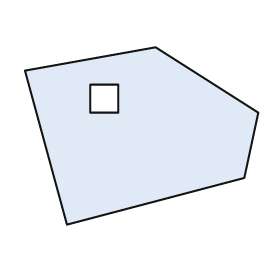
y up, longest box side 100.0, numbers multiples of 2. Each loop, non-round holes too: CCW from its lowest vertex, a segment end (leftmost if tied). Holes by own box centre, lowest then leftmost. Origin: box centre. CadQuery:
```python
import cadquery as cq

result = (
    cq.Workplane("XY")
    .moveTo(-32.0, -38.0)
    .lineTo(44.0, -18.0)
    .lineTo(50.0, 10.0)
    .lineTo(6.0, 38.0)
    .lineTo(-50.0, 28.0)
    .close()
    .moveTo(-22.0, 10.0)
    .lineTo(-10.0, 10.0)
    .lineTo(-10.0, 22.0)
    .lineTo(-22.0, 22.0)
    .close()
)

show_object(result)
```